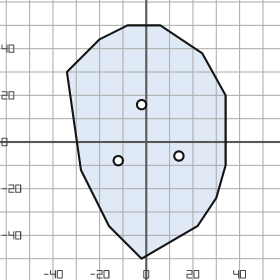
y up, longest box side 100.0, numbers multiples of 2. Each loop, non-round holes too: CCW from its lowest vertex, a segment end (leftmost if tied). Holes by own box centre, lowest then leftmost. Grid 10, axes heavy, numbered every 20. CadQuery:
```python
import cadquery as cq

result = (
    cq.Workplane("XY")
    .moveTo(-2.0, -50.0)
    .lineTo(22.0, -36.0)
    .lineTo(30.0, -24.0)
    .lineTo(34.0, -10.0)
    .lineTo(34.0, 20.0)
    .lineTo(24.0, 38.0)
    .lineTo(6.0, 50.0)
    .lineTo(-8.0, 50.0)
    .lineTo(-20.0, 44.0)
    .lineTo(-34.0, 30.0)
    .lineTo(-28.0, -12.0)
    .lineTo(-16.0, -36.0)
    .close()
    .moveTo(-12.0, -8.0)
    .circle(2.0)
    .moveTo(14.0, -6.0)
    .circle(2.0)
    .moveTo(-2.0, 16.0)
    .circle(2.0)
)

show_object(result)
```